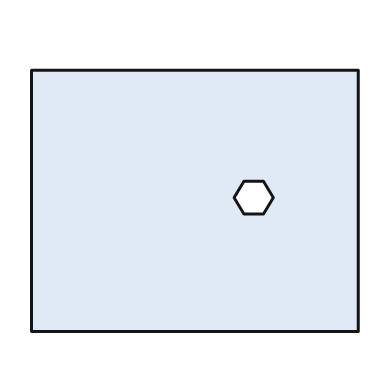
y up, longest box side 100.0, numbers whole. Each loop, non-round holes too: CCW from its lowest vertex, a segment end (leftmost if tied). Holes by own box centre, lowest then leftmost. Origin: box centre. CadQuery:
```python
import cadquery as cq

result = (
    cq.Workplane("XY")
    .moveTo(-50.0, -40.0)
    .lineTo(50.0, -40.0)
    .lineTo(50.0, 40.0)
    .lineTo(-50.0, 40.0)
    .close()
    .moveTo(15.0, -4.0)
    .lineTo(21.0, -4.0)
    .lineTo(24.0, 1.0)
    .lineTo(21.0, 6.0)
    .lineTo(15.0, 6.0)
    .lineTo(12.0, 1.0)
    .close()
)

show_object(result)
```